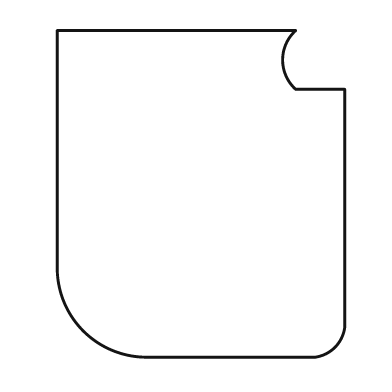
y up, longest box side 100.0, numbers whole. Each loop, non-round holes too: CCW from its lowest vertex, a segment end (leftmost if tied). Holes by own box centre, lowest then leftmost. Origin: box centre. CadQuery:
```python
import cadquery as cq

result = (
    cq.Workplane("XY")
    .moveTo(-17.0, -50.0)
    .lineTo(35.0, -50.0)
    .threePointArc((41.0, -47.0), (44.0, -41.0))
    .lineTo(44.0, 32.0)
    .lineTo(29.0, 32.0)
    .threePointArc((25.0, 41.0), (29.0, 50.0))
    .lineTo(-44.0, 50.0)
    .lineTo(-44.0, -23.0)
    .threePointArc((-36.0, -42.0), (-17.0, -50.0))
    .close()
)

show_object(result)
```